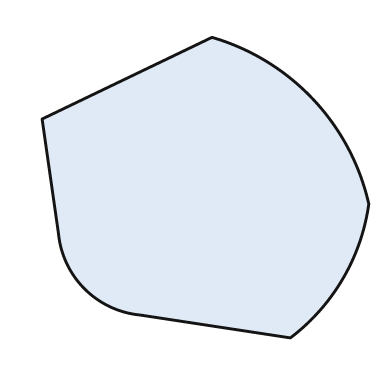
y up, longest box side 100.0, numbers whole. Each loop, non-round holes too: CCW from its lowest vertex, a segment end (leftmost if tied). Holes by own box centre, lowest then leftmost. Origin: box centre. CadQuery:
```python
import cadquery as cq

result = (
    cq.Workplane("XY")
    .moveTo(26.0, -46.0)
    .threePointArc((42.0, -28.0), (50.0, -5.0))
    .threePointArc((33.0, 27.0), (2.0, 46.0))
    .lineTo(-50.0, 21.0)
    .lineTo(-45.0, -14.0)
    .threePointArc((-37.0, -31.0), (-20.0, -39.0))
    .close()
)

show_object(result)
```